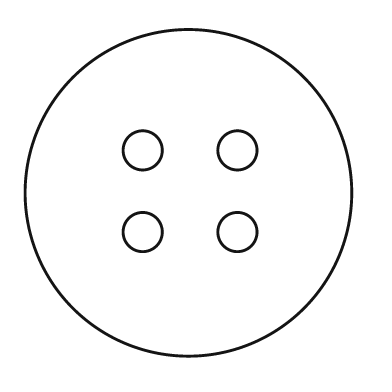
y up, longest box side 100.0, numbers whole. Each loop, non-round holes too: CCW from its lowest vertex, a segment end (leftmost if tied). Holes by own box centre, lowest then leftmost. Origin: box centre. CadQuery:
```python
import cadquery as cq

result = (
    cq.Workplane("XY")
    .moveTo(0.0, 0.0)
    .circle(50.0)
    .moveTo(-14.0, -12.0)
    .circle(6.0)
    .moveTo(15.0, -12.0)
    .circle(6.0)
    .moveTo(-14.0, 13.0)
    .circle(6.0)
    .moveTo(15.0, 13.0)
    .circle(6.0)
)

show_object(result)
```